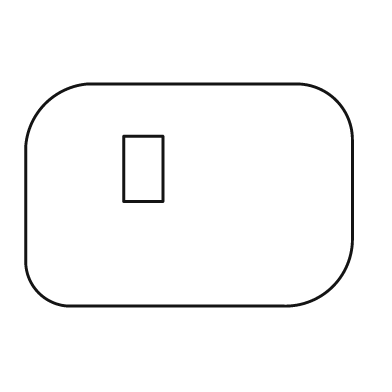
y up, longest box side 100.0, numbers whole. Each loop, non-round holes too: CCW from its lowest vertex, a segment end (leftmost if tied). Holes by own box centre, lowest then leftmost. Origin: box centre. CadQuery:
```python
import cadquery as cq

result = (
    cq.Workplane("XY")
    .moveTo(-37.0, -34.0)
    .lineTo(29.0, -34.0)
    .threePointArc((44.0, -28.0), (50.0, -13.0))
    .lineTo(50.0, 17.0)
    .threePointArc((45.0, 29.0), (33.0, 34.0))
    .lineTo(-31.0, 34.0)
    .threePointArc((-44.0, 28.0), (-50.0, 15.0))
    .lineTo(-50.0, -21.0)
    .threePointArc((-46.0, -30.0), (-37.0, -34.0))
    .close()
    .moveTo(-20.0, -2.0)
    .lineTo(-8.0, -2.0)
    .lineTo(-8.0, 18.0)
    .lineTo(-20.0, 18.0)
    .close()
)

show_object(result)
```